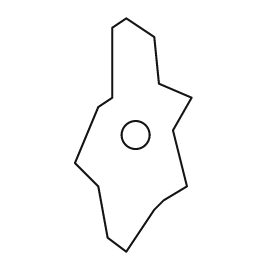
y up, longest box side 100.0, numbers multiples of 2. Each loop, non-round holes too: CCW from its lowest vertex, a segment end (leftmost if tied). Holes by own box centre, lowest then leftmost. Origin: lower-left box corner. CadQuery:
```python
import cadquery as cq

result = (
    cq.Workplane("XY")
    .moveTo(22.0, 0.0)
    .lineTo(34.0, 18.0)
    .lineTo(38.0, 22.0)
    .lineTo(48.0, 28.0)
    .lineTo(42.0, 52.0)
    .lineTo(50.0, 66.0)
    .lineTo(36.0, 72.0)
    .lineTo(34.0, 92.0)
    .lineTo(22.0, 100.0)
    .lineTo(16.0, 96.0)
    .lineTo(16.0, 66.0)
    .lineTo(10.0, 62.0)
    .lineTo(0.0, 38.0)
    .lineTo(10.0, 28.0)
    .lineTo(14.0, 6.0)
    .close()
    .moveTo(26.0, 50.0)
    .circle(6.0)
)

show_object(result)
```